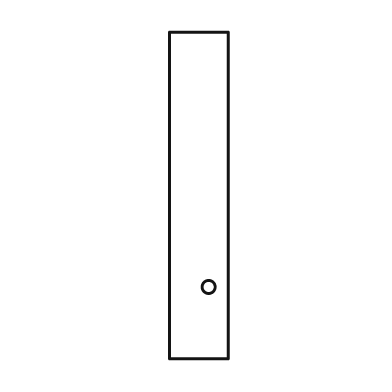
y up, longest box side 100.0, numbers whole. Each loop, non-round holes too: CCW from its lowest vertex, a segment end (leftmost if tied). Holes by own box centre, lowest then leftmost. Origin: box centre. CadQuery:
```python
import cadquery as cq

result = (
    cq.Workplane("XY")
    .moveTo(-9.0, -50.0)
    .lineTo(9.0, -50.0)
    .lineTo(9.0, 50.0)
    .lineTo(-9.0, 50.0)
    .close()
    .moveTo(3.0, -28.0)
    .circle(2.0)
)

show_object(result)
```